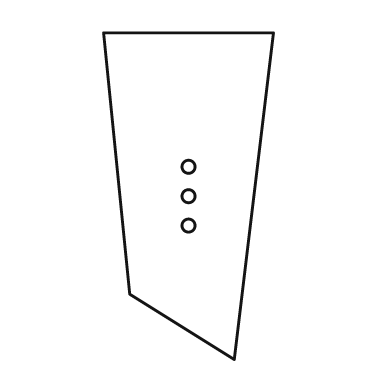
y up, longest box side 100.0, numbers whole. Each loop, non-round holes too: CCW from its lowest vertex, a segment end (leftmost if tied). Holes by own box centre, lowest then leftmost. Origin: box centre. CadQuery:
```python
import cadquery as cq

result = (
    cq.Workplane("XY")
    .moveTo(14.0, -50.0)
    .lineTo(26.0, 50.0)
    .lineTo(-26.0, 50.0)
    .lineTo(-18.0, -30.0)
    .close()
    .moveTo(0.0, -9.0)
    .circle(2.0)
    .moveTo(0.0, 0.0)
    .circle(2.0)
    .moveTo(0.0, 9.0)
    .circle(2.0)
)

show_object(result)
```